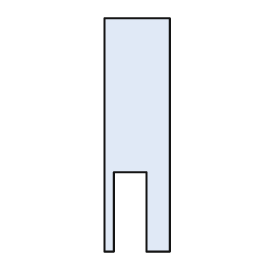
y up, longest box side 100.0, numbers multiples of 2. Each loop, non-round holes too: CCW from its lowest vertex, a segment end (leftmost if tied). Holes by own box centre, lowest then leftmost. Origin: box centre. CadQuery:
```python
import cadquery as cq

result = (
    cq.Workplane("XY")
    .moveTo(-14.0, -50.0)
    .lineTo(-10.0, -50.0)
    .lineTo(-10.0, -16.0)
    .lineTo(4.0, -16.0)
    .lineTo(4.0, -50.0)
    .lineTo(14.0, -50.0)
    .lineTo(14.0, 50.0)
    .lineTo(-14.0, 50.0)
    .close()
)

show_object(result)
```